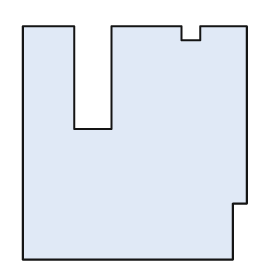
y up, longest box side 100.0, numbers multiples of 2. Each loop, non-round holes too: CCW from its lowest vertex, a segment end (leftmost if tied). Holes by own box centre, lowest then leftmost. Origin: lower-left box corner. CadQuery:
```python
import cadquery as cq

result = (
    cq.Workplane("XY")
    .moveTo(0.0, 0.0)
    .lineTo(90.0, 0.0)
    .lineTo(90.0, 24.0)
    .lineTo(96.0, 24.0)
    .lineTo(96.0, 100.0)
    .lineTo(76.0, 100.0)
    .lineTo(76.0, 94.0)
    .lineTo(68.0, 94.0)
    .lineTo(68.0, 100.0)
    .lineTo(38.0, 100.0)
    .lineTo(38.0, 56.0)
    .lineTo(22.0, 56.0)
    .lineTo(22.0, 100.0)
    .lineTo(0.0, 100.0)
    .close()
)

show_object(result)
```